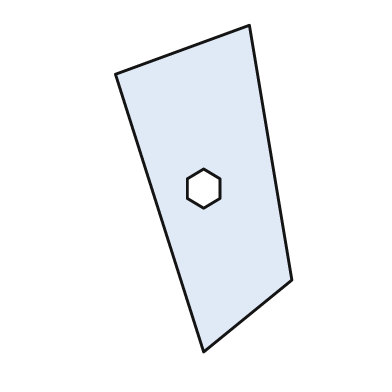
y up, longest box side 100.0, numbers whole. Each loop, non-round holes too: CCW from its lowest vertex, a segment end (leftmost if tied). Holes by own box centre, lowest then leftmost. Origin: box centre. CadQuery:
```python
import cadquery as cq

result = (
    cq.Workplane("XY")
    .moveTo(0.0, -50.0)
    .lineTo(27.0, -28.0)
    .lineTo(14.0, 50.0)
    .lineTo(-27.0, 35.0)
    .close()
    .moveTo(0.0, -6.0)
    .lineTo(5.0, -3.0)
    .lineTo(5.0, 3.0)
    .lineTo(0.0, 6.0)
    .lineTo(-5.0, 3.0)
    .lineTo(-5.0, -3.0)
    .close()
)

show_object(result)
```